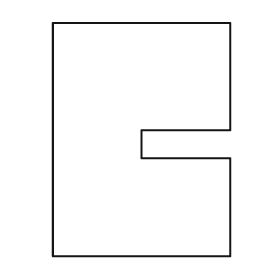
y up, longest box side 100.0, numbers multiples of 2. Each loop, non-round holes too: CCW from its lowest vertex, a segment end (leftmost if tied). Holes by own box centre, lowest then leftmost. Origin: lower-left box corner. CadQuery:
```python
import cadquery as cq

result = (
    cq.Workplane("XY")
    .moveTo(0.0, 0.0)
    .lineTo(76.0, 0.0)
    .lineTo(76.0, 42.0)
    .lineTo(38.0, 42.0)
    .lineTo(38.0, 54.0)
    .lineTo(76.0, 54.0)
    .lineTo(76.0, 100.0)
    .lineTo(0.0, 100.0)
    .close()
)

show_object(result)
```